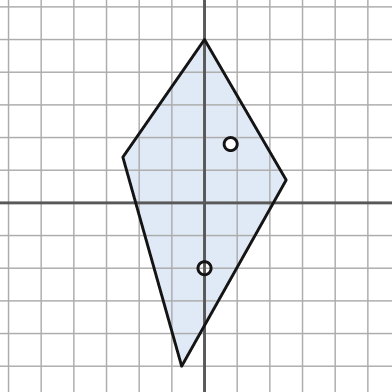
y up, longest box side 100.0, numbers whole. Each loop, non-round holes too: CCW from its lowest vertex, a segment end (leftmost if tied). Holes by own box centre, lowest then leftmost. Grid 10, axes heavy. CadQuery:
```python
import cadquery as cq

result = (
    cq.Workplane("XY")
    .moveTo(-7.0, -50.0)
    .lineTo(25.0, 7.0)
    .lineTo(0.0, 50.0)
    .lineTo(-25.0, 14.0)
    .close()
    .moveTo(0.0, -20.0)
    .circle(2.0)
    .moveTo(8.0, 18.0)
    .circle(2.0)
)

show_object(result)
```